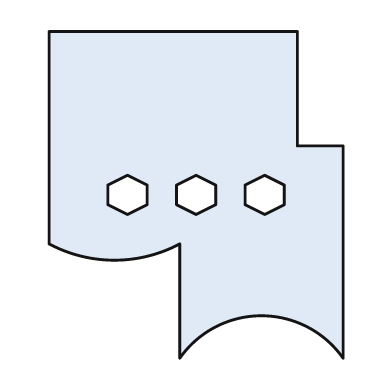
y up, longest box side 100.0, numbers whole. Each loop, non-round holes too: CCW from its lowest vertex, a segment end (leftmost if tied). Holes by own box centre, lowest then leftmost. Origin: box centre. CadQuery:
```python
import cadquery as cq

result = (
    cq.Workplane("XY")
    .moveTo(-5.0, -50.0)
    .threePointArc((20.0, -37.0), (45.0, -50.0))
    .lineTo(45.0, 15.0)
    .lineTo(31.0, 15.0)
    .lineTo(31.0, 50.0)
    .lineTo(-45.0, 50.0)
    .lineTo(-45.0, -15.0)
    .threePointArc((-25.0, -20.0), (-5.0, -15.0))
    .close()
    .moveTo(-21.0, -6.0)
    .lineTo(-15.0, -3.0)
    .lineTo(-15.0, 3.0)
    .lineTo(-21.0, 6.0)
    .lineTo(-27.0, 3.0)
    .lineTo(-27.0, -3.0)
    .close()
    .moveTo(0.0, -6.0)
    .lineTo(6.0, -3.0)
    .lineTo(6.0, 3.0)
    .lineTo(0.0, 6.0)
    .lineTo(-6.0, 3.0)
    .lineTo(-6.0, -3.0)
    .close()
    .moveTo(21.0, -6.0)
    .lineTo(27.0, -3.0)
    .lineTo(27.0, 3.0)
    .lineTo(21.0, 6.0)
    .lineTo(15.0, 3.0)
    .lineTo(15.0, -3.0)
    .close()
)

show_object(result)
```